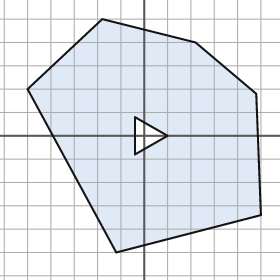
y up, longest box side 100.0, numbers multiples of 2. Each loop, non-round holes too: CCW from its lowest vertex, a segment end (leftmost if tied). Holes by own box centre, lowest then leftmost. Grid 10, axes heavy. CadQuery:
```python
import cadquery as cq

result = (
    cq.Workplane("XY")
    .moveTo(-12.0, -50.0)
    .lineTo(50.0, -34.0)
    .lineTo(48.0, 18.0)
    .lineTo(22.0, 40.0)
    .lineTo(-18.0, 50.0)
    .lineTo(-50.0, 20.0)
    .close()
    .moveTo(-4.0, -8.0)
    .lineTo(10.0, 0.0)
    .lineTo(-4.0, 8.0)
    .close()
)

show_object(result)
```